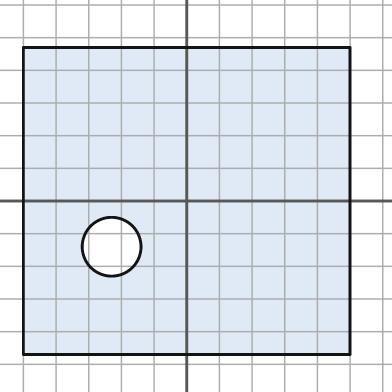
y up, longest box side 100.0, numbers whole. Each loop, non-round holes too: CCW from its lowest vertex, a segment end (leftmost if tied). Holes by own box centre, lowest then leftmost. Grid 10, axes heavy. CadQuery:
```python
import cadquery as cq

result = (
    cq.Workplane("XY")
    .moveTo(-50.0, -47.0)
    .lineTo(50.0, -47.0)
    .lineTo(50.0, 47.0)
    .lineTo(-50.0, 47.0)
    .close()
    .moveTo(-23.0, -14.0)
    .circle(9.0)
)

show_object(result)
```